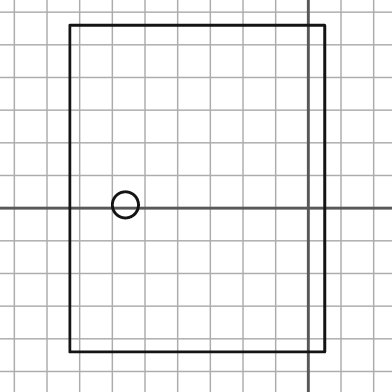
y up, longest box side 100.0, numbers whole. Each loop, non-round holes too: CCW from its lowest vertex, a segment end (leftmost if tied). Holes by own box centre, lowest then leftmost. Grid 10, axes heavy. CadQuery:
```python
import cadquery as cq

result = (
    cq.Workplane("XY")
    .moveTo(-73.0, -44.0)
    .lineTo(5.0, -44.0)
    .lineTo(5.0, 56.0)
    .lineTo(-73.0, 56.0)
    .close()
    .moveTo(-56.0, 1.0)
    .circle(4.0)
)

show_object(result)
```